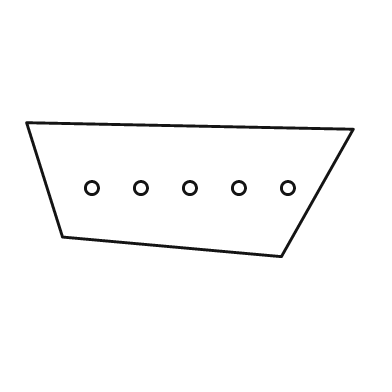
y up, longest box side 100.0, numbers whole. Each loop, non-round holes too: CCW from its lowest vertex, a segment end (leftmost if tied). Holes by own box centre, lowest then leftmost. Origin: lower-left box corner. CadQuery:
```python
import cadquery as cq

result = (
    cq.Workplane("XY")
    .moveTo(78.0, 0.0)
    .lineTo(100.0, 39.0)
    .lineTo(0.0, 41.0)
    .lineTo(11.0, 6.0)
    .close()
    .moveTo(20.0, 21.0)
    .circle(2.0)
    .moveTo(35.0, 21.0)
    .circle(2.0)
    .moveTo(50.0, 21.0)
    .circle(2.0)
    .moveTo(65.0, 21.0)
    .circle(2.0)
    .moveTo(80.0, 21.0)
    .circle(2.0)
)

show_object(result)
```